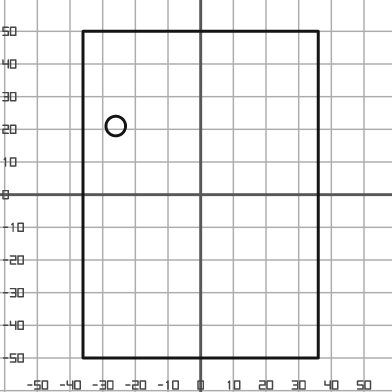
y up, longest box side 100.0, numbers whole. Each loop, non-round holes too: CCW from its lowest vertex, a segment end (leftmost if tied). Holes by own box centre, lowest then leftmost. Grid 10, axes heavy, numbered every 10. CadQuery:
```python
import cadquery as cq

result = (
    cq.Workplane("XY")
    .moveTo(-36.0, -50.0)
    .lineTo(36.0, -50.0)
    .lineTo(36.0, 50.0)
    .lineTo(-36.0, 50.0)
    .close()
    .moveTo(-26.0, 21.0)
    .circle(3.0)
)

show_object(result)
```